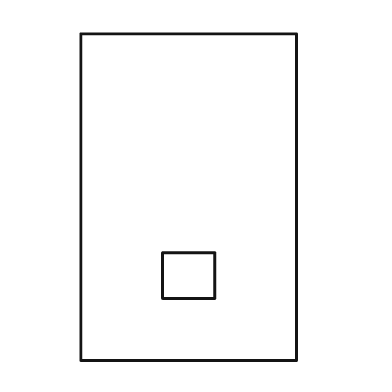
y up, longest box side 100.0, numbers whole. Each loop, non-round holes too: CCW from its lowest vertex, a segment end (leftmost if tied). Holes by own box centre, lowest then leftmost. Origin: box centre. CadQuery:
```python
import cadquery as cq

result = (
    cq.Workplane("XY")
    .moveTo(-33.0, -50.0)
    .lineTo(33.0, -50.0)
    .lineTo(33.0, 50.0)
    .lineTo(-33.0, 50.0)
    .close()
    .moveTo(-8.0, -31.0)
    .lineTo(8.0, -31.0)
    .lineTo(8.0, -17.0)
    .lineTo(-8.0, -17.0)
    .close()
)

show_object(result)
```